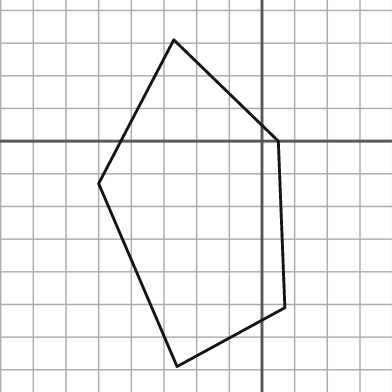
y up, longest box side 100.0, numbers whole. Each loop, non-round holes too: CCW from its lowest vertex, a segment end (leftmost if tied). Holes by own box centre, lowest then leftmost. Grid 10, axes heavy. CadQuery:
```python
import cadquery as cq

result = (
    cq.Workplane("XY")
    .moveTo(-26.0, -69.0)
    .lineTo(7.0, -51.0)
    .lineTo(5.0, 0.0)
    .lineTo(-27.0, 31.0)
    .lineTo(-50.0, -13.0)
    .close()
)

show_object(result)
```